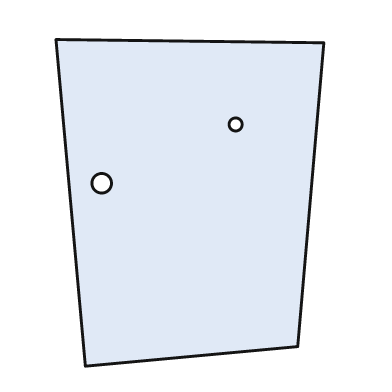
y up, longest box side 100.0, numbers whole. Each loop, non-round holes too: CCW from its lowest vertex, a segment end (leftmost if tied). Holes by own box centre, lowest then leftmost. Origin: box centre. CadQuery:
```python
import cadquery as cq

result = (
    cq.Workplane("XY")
    .moveTo(-32.0, -50.0)
    .lineTo(33.0, -44.0)
    .lineTo(41.0, 49.0)
    .lineTo(-41.0, 50.0)
    .close()
    .moveTo(-27.0, 6.0)
    .circle(3.0)
    .moveTo(14.0, 24.0)
    .circle(2.0)
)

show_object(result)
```